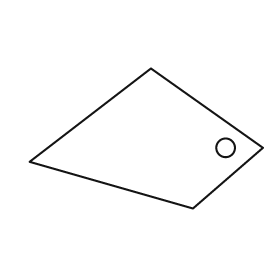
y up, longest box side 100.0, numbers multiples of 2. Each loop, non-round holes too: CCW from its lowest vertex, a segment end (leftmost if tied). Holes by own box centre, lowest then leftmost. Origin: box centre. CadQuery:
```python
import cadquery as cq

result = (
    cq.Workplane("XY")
    .moveTo(20.0, -30.0)
    .lineTo(50.0, -4.0)
    .lineTo(2.0, 30.0)
    .lineTo(-50.0, -10.0)
    .close()
    .moveTo(34.0, -4.0)
    .circle(4.0)
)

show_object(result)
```